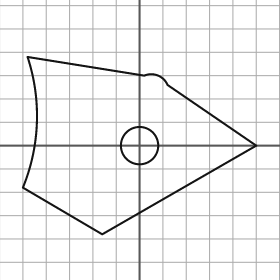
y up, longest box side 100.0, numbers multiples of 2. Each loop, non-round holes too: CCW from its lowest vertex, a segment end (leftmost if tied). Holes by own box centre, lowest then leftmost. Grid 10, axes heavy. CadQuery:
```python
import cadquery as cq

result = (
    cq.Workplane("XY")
    .moveTo(-16.0, -38.0)
    .lineTo(50.0, 0.0)
    .lineTo(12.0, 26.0)
    .threePointArc((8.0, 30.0), (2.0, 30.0))
    .lineTo(-48.0, 38.0)
    .threePointArc((-44.0, 10.0), (-50.0, -18.0))
    .close()
    .moveTo(0.0, 0.0)
    .circle(8.0)
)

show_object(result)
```